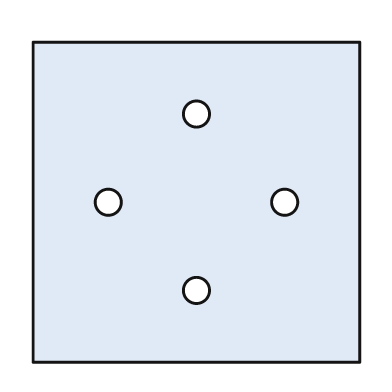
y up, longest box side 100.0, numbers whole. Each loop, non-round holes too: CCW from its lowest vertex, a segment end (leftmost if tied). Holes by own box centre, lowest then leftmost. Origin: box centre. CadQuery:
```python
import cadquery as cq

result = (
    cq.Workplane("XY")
    .moveTo(-50.0, -49.0)
    .lineTo(50.0, -49.0)
    .lineTo(50.0, 49.0)
    .lineTo(-50.0, 49.0)
    .close()
    .moveTo(0.0, -27.0)
    .circle(4.0)
    .moveTo(-27.0, 0.0)
    .circle(4.0)
    .moveTo(27.0, 0.0)
    .circle(4.0)
    .moveTo(0.0, 27.0)
    .circle(4.0)
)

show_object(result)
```